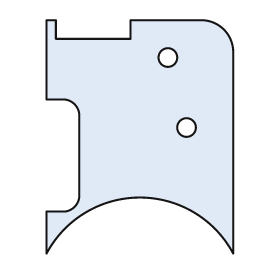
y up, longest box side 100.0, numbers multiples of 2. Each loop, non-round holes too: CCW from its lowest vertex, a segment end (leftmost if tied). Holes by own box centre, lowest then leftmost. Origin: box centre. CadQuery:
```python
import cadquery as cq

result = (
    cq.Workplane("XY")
    .moveTo(-40.0, -50.0)
    .threePointArc((0.0, -26.0), (40.0, -50.0))
    .lineTo(40.0, 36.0)
    .threePointArc((36.0, 46.0), (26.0, 50.0))
    .lineTo(-4.0, 50.0)
    .lineTo(-4.0, 42.0)
    .lineTo(-36.0, 42.0)
    .lineTo(-36.0, 50.0)
    .lineTo(-40.0, 50.0)
    .lineTo(-40.0, 16.0)
    .lineTo(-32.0, 16.0)
    .threePointArc((-28.0, 14.0), (-26.0, 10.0))
    .lineTo(-26.0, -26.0)
    .threePointArc((-28.0, -30.0), (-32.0, -32.0))
    .lineTo(-40.0, -32.0)
    .close()
    .moveTo(20.0, 4.0)
    .circle(4.0)
    .moveTo(12.0, 34.0)
    .circle(4.0)
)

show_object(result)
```